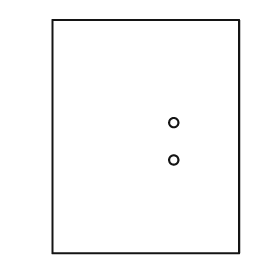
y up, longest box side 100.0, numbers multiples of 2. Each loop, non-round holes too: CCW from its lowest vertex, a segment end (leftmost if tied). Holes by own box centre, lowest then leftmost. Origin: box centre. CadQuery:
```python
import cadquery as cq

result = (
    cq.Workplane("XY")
    .moveTo(-40.0, -50.0)
    .lineTo(40.0, -50.0)
    .lineTo(40.0, 50.0)
    .lineTo(-40.0, 50.0)
    .close()
    .moveTo(12.0, -10.0)
    .circle(2.0)
    .moveTo(12.0, 6.0)
    .circle(2.0)
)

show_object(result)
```